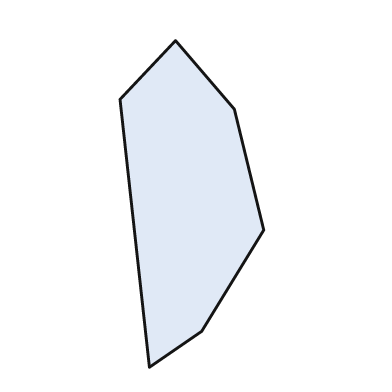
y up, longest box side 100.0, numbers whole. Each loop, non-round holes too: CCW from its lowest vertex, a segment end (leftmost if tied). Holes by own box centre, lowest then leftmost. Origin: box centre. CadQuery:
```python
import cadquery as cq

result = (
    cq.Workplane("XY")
    .moveTo(-13.0, -50.0)
    .lineTo(3.0, -39.0)
    .lineTo(22.0, -8.0)
    .lineTo(13.0, 29.0)
    .lineTo(-5.0, 50.0)
    .lineTo(-22.0, 32.0)
    .close()
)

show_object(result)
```